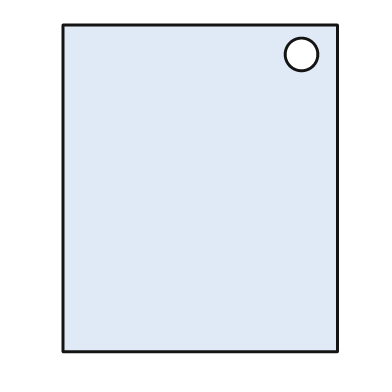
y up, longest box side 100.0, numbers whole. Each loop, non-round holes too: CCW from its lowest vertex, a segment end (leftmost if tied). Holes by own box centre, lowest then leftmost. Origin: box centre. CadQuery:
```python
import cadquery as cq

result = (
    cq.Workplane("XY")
    .moveTo(-42.0, -50.0)
    .lineTo(42.0, -50.0)
    .lineTo(42.0, 50.0)
    .lineTo(-42.0, 50.0)
    .close()
    .moveTo(31.0, 41.0)
    .circle(5.0)
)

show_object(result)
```